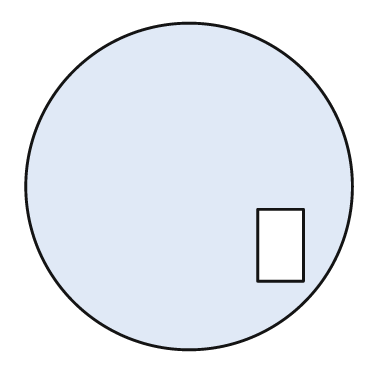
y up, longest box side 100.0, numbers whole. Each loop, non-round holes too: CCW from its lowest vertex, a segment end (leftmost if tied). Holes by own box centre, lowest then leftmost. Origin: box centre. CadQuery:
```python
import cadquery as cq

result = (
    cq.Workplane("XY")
    .moveTo(0.0, 0.0)
    .circle(50.0)
    .moveTo(21.0, -29.0)
    .lineTo(35.0, -29.0)
    .lineTo(35.0, -7.0)
    .lineTo(21.0, -7.0)
    .close()
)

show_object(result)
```